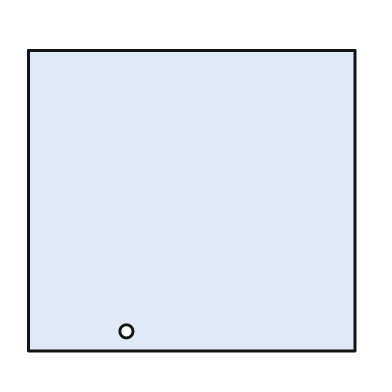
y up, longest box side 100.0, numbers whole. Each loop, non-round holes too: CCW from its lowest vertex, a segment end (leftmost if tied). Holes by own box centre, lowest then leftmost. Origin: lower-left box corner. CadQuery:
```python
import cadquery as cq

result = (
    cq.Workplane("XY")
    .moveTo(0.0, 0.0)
    .lineTo(100.0, 0.0)
    .lineTo(100.0, 92.0)
    .lineTo(0.0, 92.0)
    .close()
    .moveTo(30.0, 6.0)
    .circle(2.0)
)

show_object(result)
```